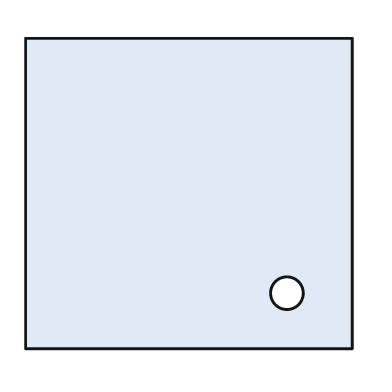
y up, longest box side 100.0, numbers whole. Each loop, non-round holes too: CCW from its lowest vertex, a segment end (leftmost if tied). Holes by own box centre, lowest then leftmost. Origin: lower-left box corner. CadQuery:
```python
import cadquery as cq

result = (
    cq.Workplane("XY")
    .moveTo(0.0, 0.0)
    .lineTo(100.0, 0.0)
    .lineTo(100.0, 95.0)
    .lineTo(0.0, 95.0)
    .close()
    .moveTo(80.0, 17.0)
    .circle(5.0)
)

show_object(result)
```